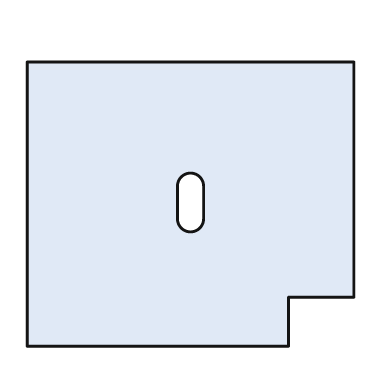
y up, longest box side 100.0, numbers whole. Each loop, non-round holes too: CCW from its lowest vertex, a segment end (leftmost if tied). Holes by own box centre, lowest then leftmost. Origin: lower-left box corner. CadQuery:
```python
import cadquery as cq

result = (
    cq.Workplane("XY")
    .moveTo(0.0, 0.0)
    .lineTo(80.0, 0.0)
    .lineTo(80.0, 15.0)
    .lineTo(100.0, 15.0)
    .lineTo(100.0, 87.0)
    .lineTo(0.0, 87.0)
    .close()
    .moveTo(46.0, 39.0)
    .threePointArc((50.0, 35.0), (54.0, 39.0))
    .lineTo(54.0, 49.0)
    .threePointArc((50.0, 53.0), (46.0, 49.0))
    .close()
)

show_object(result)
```